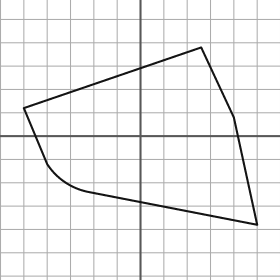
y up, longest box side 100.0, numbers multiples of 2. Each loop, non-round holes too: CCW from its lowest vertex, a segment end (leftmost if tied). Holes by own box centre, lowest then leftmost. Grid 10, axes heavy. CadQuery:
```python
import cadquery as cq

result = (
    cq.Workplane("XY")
    .moveTo(50.0, -38.0)
    .lineTo(40.0, 8.0)
    .lineTo(26.0, 38.0)
    .lineTo(-50.0, 12.0)
    .lineTo(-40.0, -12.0)
    .threePointArc((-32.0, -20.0), (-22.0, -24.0))
    .close()
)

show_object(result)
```